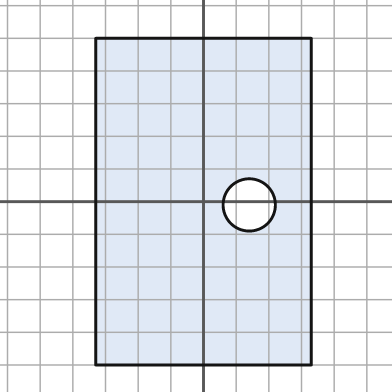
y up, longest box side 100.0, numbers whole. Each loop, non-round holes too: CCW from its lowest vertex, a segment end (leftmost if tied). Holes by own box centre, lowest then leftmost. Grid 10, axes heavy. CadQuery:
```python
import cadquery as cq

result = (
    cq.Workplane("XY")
    .moveTo(-33.0, -50.0)
    .lineTo(33.0, -50.0)
    .lineTo(33.0, 50.0)
    .lineTo(-33.0, 50.0)
    .close()
    .moveTo(14.0, -1.0)
    .circle(8.0)
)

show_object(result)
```